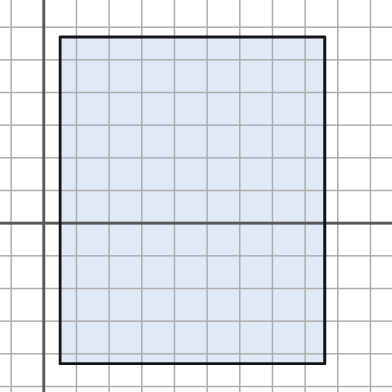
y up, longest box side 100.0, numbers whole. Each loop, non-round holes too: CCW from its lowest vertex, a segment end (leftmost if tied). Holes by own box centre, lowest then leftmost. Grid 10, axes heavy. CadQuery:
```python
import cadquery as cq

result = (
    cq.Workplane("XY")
    .moveTo(5.0, -43.0)
    .lineTo(86.0, -43.0)
    .lineTo(86.0, 57.0)
    .lineTo(5.0, 57.0)
    .close()
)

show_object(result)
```